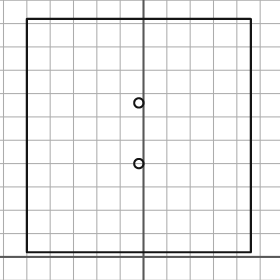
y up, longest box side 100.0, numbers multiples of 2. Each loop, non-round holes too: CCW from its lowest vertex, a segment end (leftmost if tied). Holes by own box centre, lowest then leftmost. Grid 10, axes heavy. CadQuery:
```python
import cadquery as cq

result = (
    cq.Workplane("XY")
    .moveTo(-50.0, 2.0)
    .lineTo(46.0, 2.0)
    .lineTo(46.0, 102.0)
    .lineTo(-50.0, 102.0)
    .close()
    .moveTo(-2.0, 40.0)
    .circle(2.0)
    .moveTo(-2.0, 66.0)
    .circle(2.0)
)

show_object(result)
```